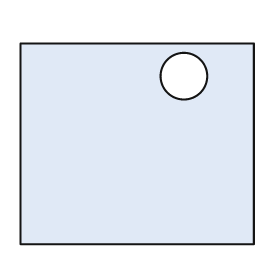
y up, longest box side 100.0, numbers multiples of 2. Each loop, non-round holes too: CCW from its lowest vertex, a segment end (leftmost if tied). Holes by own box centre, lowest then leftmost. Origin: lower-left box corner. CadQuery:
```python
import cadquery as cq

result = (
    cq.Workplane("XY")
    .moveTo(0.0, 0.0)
    .lineTo(100.0, 0.0)
    .lineTo(100.0, 86.0)
    .lineTo(0.0, 86.0)
    .close()
    .moveTo(70.0, 72.0)
    .circle(10.0)
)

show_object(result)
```